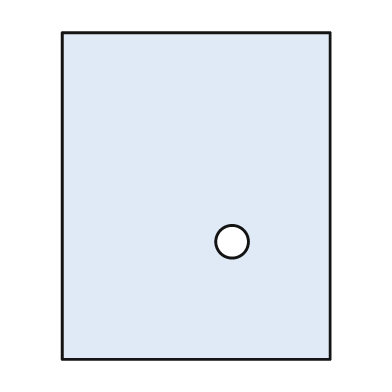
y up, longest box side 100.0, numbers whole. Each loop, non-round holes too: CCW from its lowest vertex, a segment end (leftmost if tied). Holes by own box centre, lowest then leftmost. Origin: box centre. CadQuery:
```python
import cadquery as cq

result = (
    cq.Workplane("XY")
    .moveTo(-41.0, -50.0)
    .lineTo(41.0, -50.0)
    .lineTo(41.0, 50.0)
    .lineTo(-41.0, 50.0)
    .close()
    .moveTo(11.0, -14.0)
    .circle(5.0)
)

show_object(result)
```